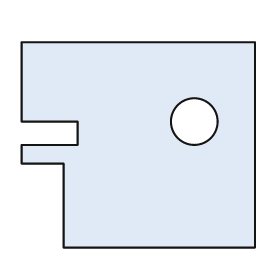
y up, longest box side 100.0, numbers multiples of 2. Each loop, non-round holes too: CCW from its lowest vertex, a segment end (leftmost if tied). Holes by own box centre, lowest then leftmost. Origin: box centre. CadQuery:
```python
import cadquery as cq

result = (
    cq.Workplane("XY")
    .moveTo(-32.0, -44.0)
    .lineTo(50.0, -44.0)
    .lineTo(50.0, 44.0)
    .lineTo(-50.0, 44.0)
    .lineTo(-50.0, 10.0)
    .lineTo(-26.0, 10.0)
    .lineTo(-26.0, 0.0)
    .lineTo(-50.0, 0.0)
    .lineTo(-50.0, -8.0)
    .lineTo(-32.0, -8.0)
    .close()
    .moveTo(24.0, 10.0)
    .circle(10.0)
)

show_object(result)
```